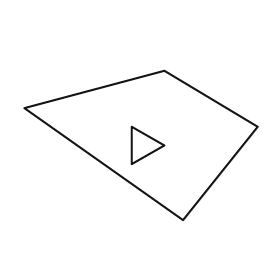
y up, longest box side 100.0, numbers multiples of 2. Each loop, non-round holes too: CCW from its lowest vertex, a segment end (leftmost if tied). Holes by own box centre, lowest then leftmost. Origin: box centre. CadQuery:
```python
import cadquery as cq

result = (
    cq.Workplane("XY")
    .moveTo(18.0, -32.0)
    .lineTo(50.0, 8.0)
    .lineTo(10.0, 32.0)
    .lineTo(-50.0, 16.0)
    .close()
    .moveTo(-4.0, -8.0)
    .lineTo(10.0, 0.0)
    .lineTo(-4.0, 8.0)
    .close()
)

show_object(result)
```